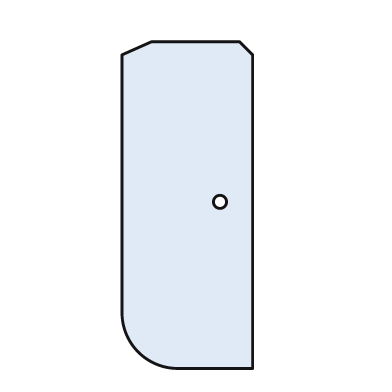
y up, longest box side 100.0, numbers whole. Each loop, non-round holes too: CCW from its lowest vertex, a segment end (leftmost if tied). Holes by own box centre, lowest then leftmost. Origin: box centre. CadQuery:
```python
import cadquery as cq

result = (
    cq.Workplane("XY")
    .moveTo(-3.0, -50.0)
    .lineTo(20.0, -50.0)
    .lineTo(20.0, 46.0)
    .lineTo(16.0, 50.0)
    .lineTo(-11.0, 50.0)
    .lineTo(-20.0, 46.0)
    .lineTo(-20.0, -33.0)
    .threePointArc((-15.0, -45.0), (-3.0, -50.0))
    .close()
    .moveTo(10.0, 1.0)
    .circle(2.0)
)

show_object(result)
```